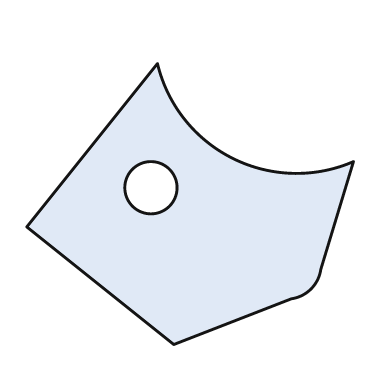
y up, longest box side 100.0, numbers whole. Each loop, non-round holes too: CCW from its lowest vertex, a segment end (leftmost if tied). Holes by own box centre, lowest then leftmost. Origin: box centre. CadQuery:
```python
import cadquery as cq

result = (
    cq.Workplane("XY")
    .moveTo(-5.0, -43.0)
    .lineTo(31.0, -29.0)
    .threePointArc((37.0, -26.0), (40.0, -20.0))
    .lineTo(50.0, 13.0)
    .threePointArc((13.0, 14.0), (-10.0, 43.0))
    .lineTo(-50.0, -7.0)
    .close()
    .moveTo(-12.0, 5.0)
    .circle(8.0)
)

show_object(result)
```